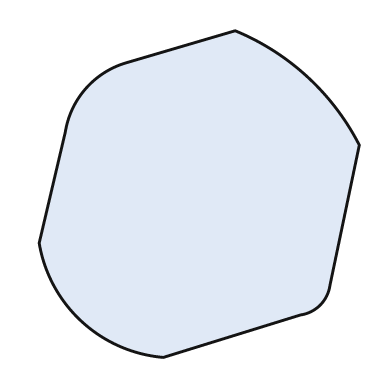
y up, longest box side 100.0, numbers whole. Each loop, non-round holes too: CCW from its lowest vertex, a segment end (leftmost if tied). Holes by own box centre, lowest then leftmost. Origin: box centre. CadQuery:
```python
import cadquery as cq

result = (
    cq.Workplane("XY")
    .moveTo(-11.0, -50.0)
    .lineTo(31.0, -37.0)
    .threePointArc((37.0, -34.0), (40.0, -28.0))
    .lineTo(49.0, 15.0)
    .threePointArc((33.0, 36.0), (11.0, 50.0))
    .lineTo(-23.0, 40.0)
    .threePointArc((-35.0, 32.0), (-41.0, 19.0))
    .lineTo(-49.0, -15.0)
    .threePointArc((-36.0, -39.0), (-11.0, -50.0))
    .close()
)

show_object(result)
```